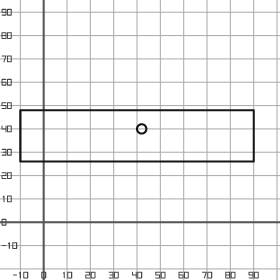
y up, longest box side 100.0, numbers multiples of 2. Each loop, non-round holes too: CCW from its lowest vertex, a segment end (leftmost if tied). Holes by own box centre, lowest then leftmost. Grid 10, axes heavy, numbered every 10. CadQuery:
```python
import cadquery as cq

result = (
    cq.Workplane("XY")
    .moveTo(-10.0, 26.0)
    .lineTo(90.0, 26.0)
    .lineTo(90.0, 48.0)
    .lineTo(-10.0, 48.0)
    .close()
    .moveTo(42.0, 40.0)
    .circle(2.0)
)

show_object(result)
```